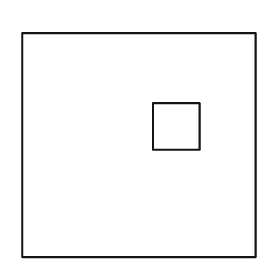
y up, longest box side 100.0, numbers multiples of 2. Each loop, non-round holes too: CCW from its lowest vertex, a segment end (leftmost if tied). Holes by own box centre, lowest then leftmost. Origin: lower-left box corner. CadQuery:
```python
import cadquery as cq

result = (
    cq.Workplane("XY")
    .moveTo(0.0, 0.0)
    .lineTo(100.0, 0.0)
    .lineTo(100.0, 96.0)
    .lineTo(0.0, 96.0)
    .close()
    .moveTo(56.0, 46.0)
    .lineTo(76.0, 46.0)
    .lineTo(76.0, 66.0)
    .lineTo(56.0, 66.0)
    .close()
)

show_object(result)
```